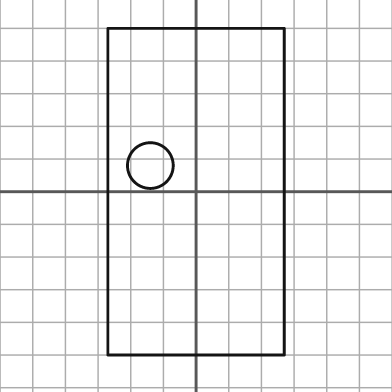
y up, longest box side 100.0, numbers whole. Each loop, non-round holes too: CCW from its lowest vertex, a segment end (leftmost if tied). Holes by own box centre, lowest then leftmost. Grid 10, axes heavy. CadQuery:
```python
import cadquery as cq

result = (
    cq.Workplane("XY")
    .moveTo(-27.0, -50.0)
    .lineTo(27.0, -50.0)
    .lineTo(27.0, 50.0)
    .lineTo(-27.0, 50.0)
    .close()
    .moveTo(-14.0, 8.0)
    .circle(7.0)
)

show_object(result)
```